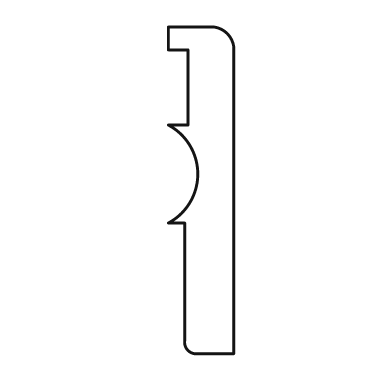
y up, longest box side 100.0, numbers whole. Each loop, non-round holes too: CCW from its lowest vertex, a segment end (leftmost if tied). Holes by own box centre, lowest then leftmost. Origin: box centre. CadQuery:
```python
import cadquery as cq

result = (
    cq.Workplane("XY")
    .moveTo(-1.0, -50.0)
    .lineTo(10.0, -50.0)
    .lineTo(10.0, 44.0)
    .threePointArc((8.0, 48.0), (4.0, 50.0))
    .lineTo(-10.0, 50.0)
    .lineTo(-10.0, 43.0)
    .lineTo(-4.0, 43.0)
    .lineTo(-4.0, 20.0)
    .lineTo(-10.0, 20.0)
    .threePointArc((-1.0, 5.0), (-10.0, -10.0))
    .lineTo(-5.0, -10.0)
    .lineTo(-5.0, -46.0)
    .threePointArc((-4.0, -49.0), (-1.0, -50.0))
    .close()
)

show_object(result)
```